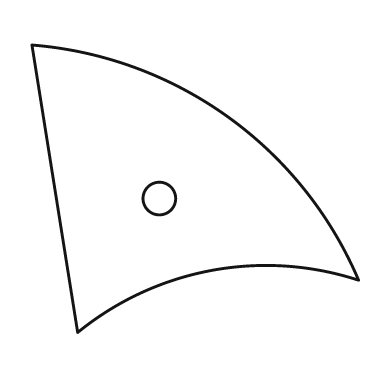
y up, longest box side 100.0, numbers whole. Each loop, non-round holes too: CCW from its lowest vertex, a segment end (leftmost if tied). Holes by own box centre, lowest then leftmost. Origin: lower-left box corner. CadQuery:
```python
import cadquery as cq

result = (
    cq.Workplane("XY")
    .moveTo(14.0, 0.0)
    .threePointArc((55.0, 19.0), (100.0, 16.0))
    .threePointArc((60.0, 66.0), (0.0, 88.0))
    .close()
    .moveTo(39.0, 41.0)
    .circle(5.0)
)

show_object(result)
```